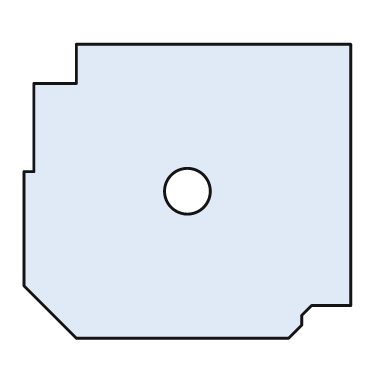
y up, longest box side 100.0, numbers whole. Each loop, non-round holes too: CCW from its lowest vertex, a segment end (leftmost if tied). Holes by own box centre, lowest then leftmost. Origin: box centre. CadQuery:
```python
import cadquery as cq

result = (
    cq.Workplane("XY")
    .moveTo(-34.0, -45.0)
    .lineTo(31.0, -45.0)
    .lineTo(35.0, -41.0)
    .lineTo(35.0, -38.0)
    .lineTo(38.0, -35.0)
    .lineTo(50.0, -35.0)
    .lineTo(50.0, 45.0)
    .lineTo(-34.0, 45.0)
    .lineTo(-34.0, 33.0)
    .lineTo(-47.0, 33.0)
    .lineTo(-47.0, 6.0)
    .lineTo(-50.0, 6.0)
    .lineTo(-50.0, -29.0)
    .close()
    .moveTo(0.0, 0.0)
    .circle(7.0)
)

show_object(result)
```